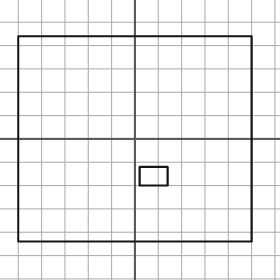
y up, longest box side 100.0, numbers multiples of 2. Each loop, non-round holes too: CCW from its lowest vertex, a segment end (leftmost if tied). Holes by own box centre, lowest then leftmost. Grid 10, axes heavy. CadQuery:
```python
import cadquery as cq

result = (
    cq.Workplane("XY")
    .moveTo(-50.0, -44.0)
    .lineTo(50.0, -44.0)
    .lineTo(50.0, 44.0)
    .lineTo(-50.0, 44.0)
    .close()
    .moveTo(2.0, -20.0)
    .lineTo(14.0, -20.0)
    .lineTo(14.0, -12.0)
    .lineTo(2.0, -12.0)
    .close()
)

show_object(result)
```